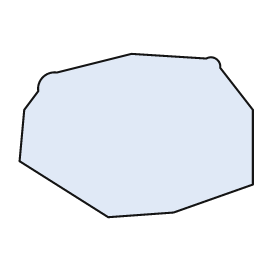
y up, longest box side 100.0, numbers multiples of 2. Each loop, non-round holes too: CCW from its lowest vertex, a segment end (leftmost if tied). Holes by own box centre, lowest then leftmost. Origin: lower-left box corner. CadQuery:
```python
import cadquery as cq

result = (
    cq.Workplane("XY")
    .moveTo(38.0, 0.0)
    .lineTo(66.0, 2.0)
    .lineTo(100.0, 14.0)
    .lineTo(100.0, 46.0)
    .lineTo(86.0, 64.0)
    .threePointArc((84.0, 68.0), (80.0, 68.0))
    .lineTo(48.0, 70.0)
    .lineTo(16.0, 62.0)
    .threePointArc((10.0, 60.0), (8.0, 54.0))
    .lineTo(2.0, 46.0)
    .lineTo(0.0, 24.0)
    .close()
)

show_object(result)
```